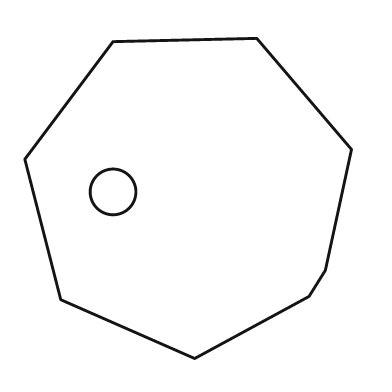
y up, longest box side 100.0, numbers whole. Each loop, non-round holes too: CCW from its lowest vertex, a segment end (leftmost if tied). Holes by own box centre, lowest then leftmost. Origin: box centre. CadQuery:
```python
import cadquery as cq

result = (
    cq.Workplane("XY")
    .moveTo(2.0, -49.0)
    .lineTo(37.0, -30.0)
    .lineTo(42.0, -22.0)
    .lineTo(50.0, 15.0)
    .lineTo(21.0, 49.0)
    .lineTo(-23.0, 48.0)
    .lineTo(-50.0, 12.0)
    .lineTo(-39.0, -31.0)
    .close()
    .moveTo(-23.0, 2.0)
    .circle(7.0)
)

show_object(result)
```